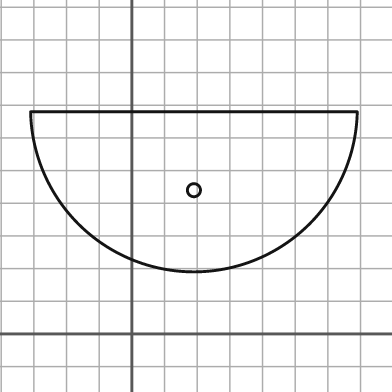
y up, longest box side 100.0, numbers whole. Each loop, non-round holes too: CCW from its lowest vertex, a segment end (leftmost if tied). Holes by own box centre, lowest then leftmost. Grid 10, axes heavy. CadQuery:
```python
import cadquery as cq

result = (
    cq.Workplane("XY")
    .moveTo(-31.0, 68.0)
    .threePointArc((19.0, 19.0), (69.0, 68.0))
    .close()
    .moveTo(19.0, 44.0)
    .circle(2.0)
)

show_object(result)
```